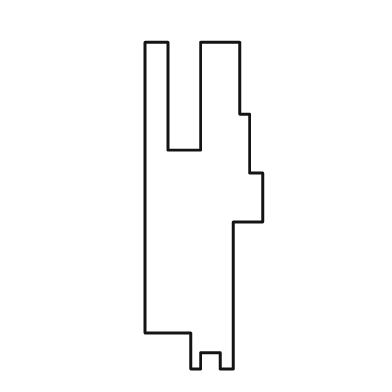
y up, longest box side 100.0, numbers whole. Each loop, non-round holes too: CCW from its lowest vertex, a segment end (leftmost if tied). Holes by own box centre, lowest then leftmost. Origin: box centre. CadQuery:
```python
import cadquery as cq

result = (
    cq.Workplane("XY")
    .moveTo(-4.0, -50.0)
    .lineTo(-1.0, -50.0)
    .lineTo(-1.0, -45.0)
    .lineTo(5.0, -45.0)
    .lineTo(5.0, -50.0)
    .lineTo(9.0, -50.0)
    .lineTo(9.0, -5.0)
    .lineTo(18.0, -5.0)
    .lineTo(18.0, 10.0)
    .lineTo(14.0, 10.0)
    .lineTo(14.0, 28.0)
    .lineTo(11.0, 28.0)
    .lineTo(11.0, 50.0)
    .lineTo(-1.0, 50.0)
    .lineTo(-1.0, 17.0)
    .lineTo(-11.0, 17.0)
    .lineTo(-11.0, 50.0)
    .lineTo(-18.0, 50.0)
    .lineTo(-18.0, -39.0)
    .lineTo(-4.0, -39.0)
    .close()
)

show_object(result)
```